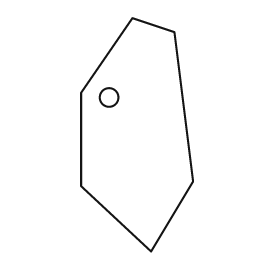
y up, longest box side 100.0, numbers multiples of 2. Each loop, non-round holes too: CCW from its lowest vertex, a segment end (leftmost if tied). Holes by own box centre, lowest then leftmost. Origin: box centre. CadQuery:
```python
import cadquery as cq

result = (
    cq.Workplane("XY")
    .moveTo(6.0, -50.0)
    .lineTo(24.0, -20.0)
    .lineTo(16.0, 44.0)
    .lineTo(-2.0, 50.0)
    .lineTo(-24.0, 18.0)
    .lineTo(-24.0, -22.0)
    .close()
    .moveTo(-12.0, 16.0)
    .circle(4.0)
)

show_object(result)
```